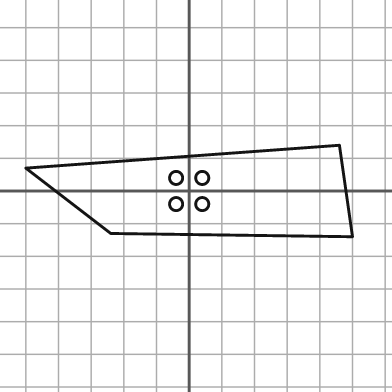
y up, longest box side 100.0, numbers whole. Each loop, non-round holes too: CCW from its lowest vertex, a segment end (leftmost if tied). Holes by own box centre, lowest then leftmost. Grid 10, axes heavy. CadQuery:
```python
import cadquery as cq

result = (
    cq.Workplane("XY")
    .moveTo(50.0, -14.0)
    .lineTo(46.0, 14.0)
    .lineTo(-50.0, 7.0)
    .lineTo(-24.0, -13.0)
    .close()
    .moveTo(-4.0, -4.0)
    .circle(2.0)
    .moveTo(4.0, -4.0)
    .circle(2.0)
    .moveTo(-4.0, 4.0)
    .circle(2.0)
    .moveTo(4.0, 4.0)
    .circle(2.0)
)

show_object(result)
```